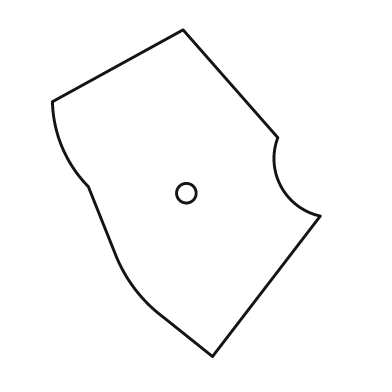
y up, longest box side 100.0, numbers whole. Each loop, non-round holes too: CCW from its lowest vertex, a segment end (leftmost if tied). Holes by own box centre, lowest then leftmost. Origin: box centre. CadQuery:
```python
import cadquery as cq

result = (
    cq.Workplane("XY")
    .moveTo(8.0, -50.0)
    .lineTo(41.0, -7.0)
    .threePointArc((29.0, 2.0), (28.0, 17.0))
    .lineTo(-1.0, 50.0)
    .lineTo(-41.0, 28.0)
    .threePointArc((-38.0, 14.0), (-30.0, 2.0))
    .lineTo(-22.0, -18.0)
    .threePointArc((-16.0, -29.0), (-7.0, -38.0))
    .close()
    .moveTo(0.0, 0.0)
    .circle(3.0)
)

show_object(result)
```